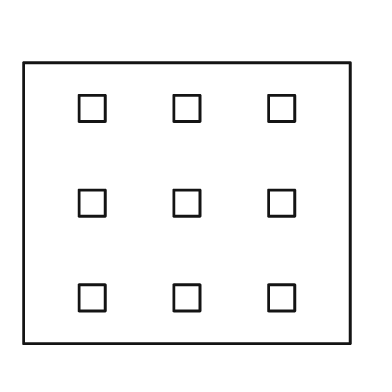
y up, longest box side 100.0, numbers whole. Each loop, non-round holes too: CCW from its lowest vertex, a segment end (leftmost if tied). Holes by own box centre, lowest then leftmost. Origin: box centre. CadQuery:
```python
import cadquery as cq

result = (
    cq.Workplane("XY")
    .moveTo(-50.0, -43.0)
    .lineTo(50.0, -43.0)
    .lineTo(50.0, 43.0)
    .lineTo(-50.0, 43.0)
    .close()
    .moveTo(-33.0, -33.0)
    .lineTo(-25.0, -33.0)
    .lineTo(-25.0, -25.0)
    .lineTo(-33.0, -25.0)
    .close()
    .moveTo(-4.0, -33.0)
    .lineTo(4.0, -33.0)
    .lineTo(4.0, -25.0)
    .lineTo(-4.0, -25.0)
    .close()
    .moveTo(25.0, -33.0)
    .lineTo(33.0, -33.0)
    .lineTo(33.0, -25.0)
    .lineTo(25.0, -25.0)
    .close()
    .moveTo(-33.0, -4.0)
    .lineTo(-25.0, -4.0)
    .lineTo(-25.0, 4.0)
    .lineTo(-33.0, 4.0)
    .close()
    .moveTo(-4.0, -4.0)
    .lineTo(4.0, -4.0)
    .lineTo(4.0, 4.0)
    .lineTo(-4.0, 4.0)
    .close()
    .moveTo(25.0, -4.0)
    .lineTo(33.0, -4.0)
    .lineTo(33.0, 4.0)
    .lineTo(25.0, 4.0)
    .close()
    .moveTo(-33.0, 25.0)
    .lineTo(-25.0, 25.0)
    .lineTo(-25.0, 33.0)
    .lineTo(-33.0, 33.0)
    .close()
    .moveTo(-4.0, 25.0)
    .lineTo(4.0, 25.0)
    .lineTo(4.0, 33.0)
    .lineTo(-4.0, 33.0)
    .close()
    .moveTo(25.0, 25.0)
    .lineTo(33.0, 25.0)
    .lineTo(33.0, 33.0)
    .lineTo(25.0, 33.0)
    .close()
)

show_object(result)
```